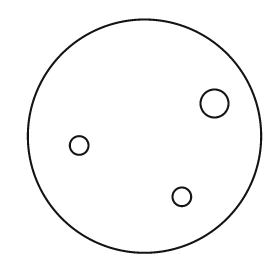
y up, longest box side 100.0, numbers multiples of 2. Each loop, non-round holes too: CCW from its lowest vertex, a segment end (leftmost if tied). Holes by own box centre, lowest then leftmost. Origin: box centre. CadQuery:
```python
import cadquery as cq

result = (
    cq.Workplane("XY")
    .moveTo(0.0, 0.0)
    .circle(50.0)
    .moveTo(16.0, -26.0)
    .circle(4.0)
    .moveTo(-28.0, -4.0)
    .circle(4.0)
    .moveTo(30.0, 14.0)
    .circle(6.0)
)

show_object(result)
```